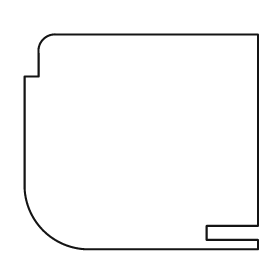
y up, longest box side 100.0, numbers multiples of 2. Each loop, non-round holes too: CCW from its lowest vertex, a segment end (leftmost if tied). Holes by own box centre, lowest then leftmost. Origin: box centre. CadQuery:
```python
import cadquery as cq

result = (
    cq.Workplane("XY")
    .moveTo(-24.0, -46.0)
    .lineTo(50.0, -46.0)
    .lineTo(50.0, -42.0)
    .lineTo(28.0, -42.0)
    .lineTo(28.0, -36.0)
    .lineTo(50.0, -36.0)
    .lineTo(50.0, 46.0)
    .lineTo(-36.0, 46.0)
    .threePointArc((-42.0, 44.0), (-44.0, 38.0))
    .lineTo(-44.0, 28.0)
    .lineTo(-50.0, 28.0)
    .lineTo(-50.0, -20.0)
    .threePointArc((-42.0, -38.0), (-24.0, -46.0))
    .close()
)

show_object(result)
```